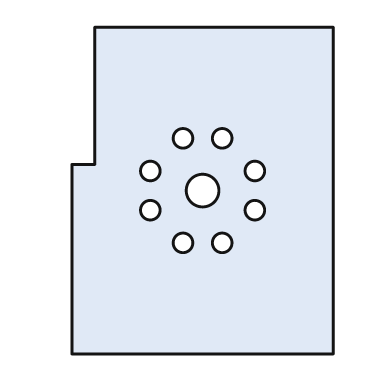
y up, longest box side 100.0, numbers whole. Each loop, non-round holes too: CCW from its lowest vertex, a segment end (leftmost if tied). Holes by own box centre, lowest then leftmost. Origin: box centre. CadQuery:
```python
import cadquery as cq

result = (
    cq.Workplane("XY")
    .moveTo(-40.0, -50.0)
    .lineTo(40.0, -50.0)
    .lineTo(40.0, 50.0)
    .lineTo(-33.0, 50.0)
    .lineTo(-33.0, 8.0)
    .lineTo(-40.0, 8.0)
    .close()
    .moveTo(-6.0, -16.0)
    .circle(3.0)
    .moveTo(6.0, -16.0)
    .circle(3.0)
    .moveTo(-16.0, -6.0)
    .circle(3.0)
    .moveTo(16.0, -6.0)
    .circle(3.0)
    .moveTo(0.0, 0.0)
    .circle(5.0)
    .moveTo(-16.0, 6.0)
    .circle(3.0)
    .moveTo(16.0, 6.0)
    .circle(3.0)
    .moveTo(-6.0, 16.0)
    .circle(3.0)
    .moveTo(6.0, 16.0)
    .circle(3.0)
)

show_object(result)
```